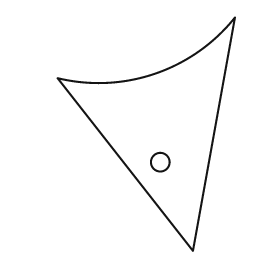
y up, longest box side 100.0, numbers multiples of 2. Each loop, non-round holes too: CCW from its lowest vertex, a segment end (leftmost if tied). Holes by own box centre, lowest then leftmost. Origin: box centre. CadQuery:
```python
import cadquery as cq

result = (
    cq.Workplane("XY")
    .moveTo(20.0, -50.0)
    .lineTo(38.0, 50.0)
    .threePointArc((4.0, 26.0), (-38.0, 24.0))
    .close()
    .moveTo(6.0, -12.0)
    .circle(4.0)
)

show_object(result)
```